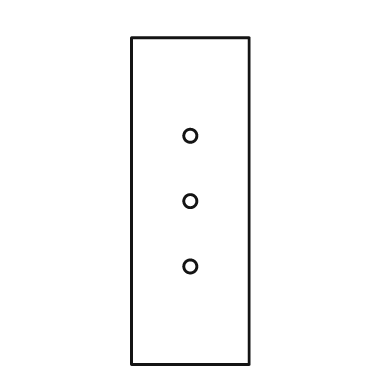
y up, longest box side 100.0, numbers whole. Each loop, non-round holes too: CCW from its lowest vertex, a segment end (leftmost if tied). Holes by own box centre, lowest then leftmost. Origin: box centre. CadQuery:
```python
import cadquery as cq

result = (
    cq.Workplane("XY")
    .moveTo(-18.0, -50.0)
    .lineTo(18.0, -50.0)
    .lineTo(18.0, 50.0)
    .lineTo(-18.0, 50.0)
    .close()
    .moveTo(0.0, -20.0)
    .circle(2.0)
    .moveTo(0.0, 0.0)
    .circle(2.0)
    .moveTo(0.0, 20.0)
    .circle(2.0)
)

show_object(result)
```